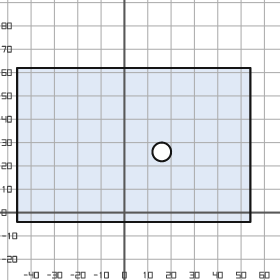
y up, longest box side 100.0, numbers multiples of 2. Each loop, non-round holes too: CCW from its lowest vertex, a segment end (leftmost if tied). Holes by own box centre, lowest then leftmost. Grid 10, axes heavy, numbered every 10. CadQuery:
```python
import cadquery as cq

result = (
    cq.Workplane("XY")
    .moveTo(-46.0, -4.0)
    .lineTo(54.0, -4.0)
    .lineTo(54.0, 62.0)
    .lineTo(-46.0, 62.0)
    .close()
    .moveTo(16.0, 26.0)
    .circle(4.0)
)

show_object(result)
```